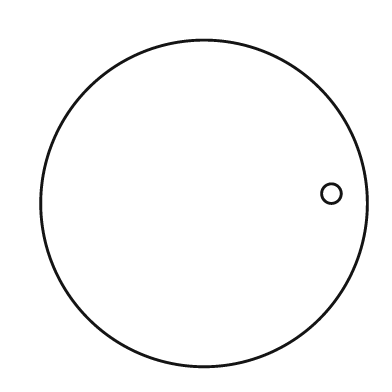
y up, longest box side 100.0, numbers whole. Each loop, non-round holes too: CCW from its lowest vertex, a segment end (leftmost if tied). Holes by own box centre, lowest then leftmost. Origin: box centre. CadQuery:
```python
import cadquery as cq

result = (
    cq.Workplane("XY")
    .moveTo(0.0, 0.0)
    .circle(50.0)
    .moveTo(39.0, 3.0)
    .circle(3.0)
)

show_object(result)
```